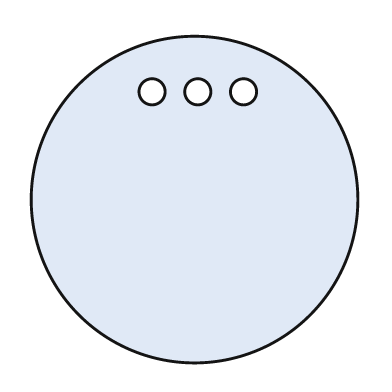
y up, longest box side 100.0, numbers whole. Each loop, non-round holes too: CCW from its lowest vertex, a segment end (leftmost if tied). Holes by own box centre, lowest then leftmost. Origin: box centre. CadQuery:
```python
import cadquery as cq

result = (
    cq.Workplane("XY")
    .moveTo(0.0, 0.0)
    .circle(50.0)
    .moveTo(-13.0, 33.0)
    .circle(4.0)
    .moveTo(1.0, 33.0)
    .circle(4.0)
    .moveTo(15.0, 33.0)
    .circle(4.0)
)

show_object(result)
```